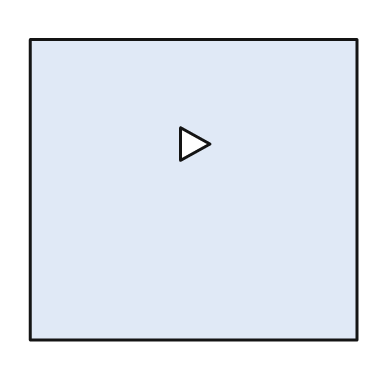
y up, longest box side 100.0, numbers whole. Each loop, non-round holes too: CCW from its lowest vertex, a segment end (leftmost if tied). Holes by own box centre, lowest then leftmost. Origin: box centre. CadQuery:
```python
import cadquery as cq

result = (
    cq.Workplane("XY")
    .moveTo(-50.0, -46.0)
    .lineTo(50.0, -46.0)
    .lineTo(50.0, 46.0)
    .lineTo(-50.0, 46.0)
    .close()
    .moveTo(-4.0, 9.0)
    .lineTo(5.0, 14.0)
    .lineTo(-4.0, 19.0)
    .close()
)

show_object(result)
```